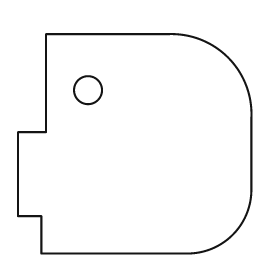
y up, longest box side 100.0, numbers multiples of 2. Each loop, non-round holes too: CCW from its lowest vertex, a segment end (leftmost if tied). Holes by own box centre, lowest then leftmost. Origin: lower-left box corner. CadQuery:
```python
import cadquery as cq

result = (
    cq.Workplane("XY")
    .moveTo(10.0, 0.0)
    .lineTo(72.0, 0.0)
    .threePointArc((92.0, 8.0), (100.0, 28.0))
    .lineTo(100.0, 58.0)
    .threePointArc((90.0, 84.0), (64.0, 94.0))
    .lineTo(12.0, 94.0)
    .lineTo(12.0, 52.0)
    .lineTo(0.0, 52.0)
    .lineTo(0.0, 16.0)
    .lineTo(10.0, 16.0)
    .close()
    .moveTo(30.0, 70.0)
    .circle(6.0)
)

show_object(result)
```